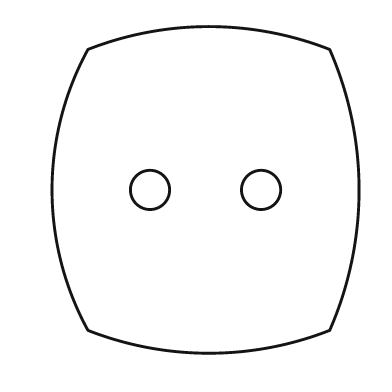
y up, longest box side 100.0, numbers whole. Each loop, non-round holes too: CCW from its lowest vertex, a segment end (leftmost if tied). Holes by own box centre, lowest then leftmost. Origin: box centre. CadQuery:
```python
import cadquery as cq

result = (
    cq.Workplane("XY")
    .moveTo(-36.0, -43.0)
    .threePointArc((1.0, -50.0), (38.0, -43.0))
    .threePointArc((47.0, 0.0), (38.0, 43.0))
    .threePointArc((1.0, 50.0), (-36.0, 43.0))
    .threePointArc((-47.0, 0.0), (-36.0, -43.0))
    .close()
    .moveTo(-17.0, 0.0)
    .circle(6.0)
    .moveTo(17.0, 0.0)
    .circle(6.0)
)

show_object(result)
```